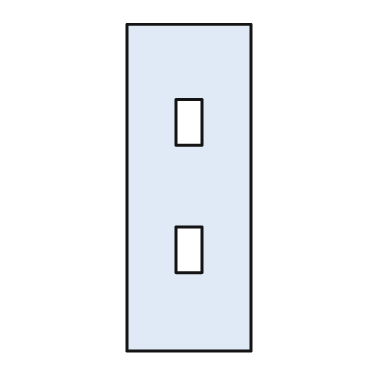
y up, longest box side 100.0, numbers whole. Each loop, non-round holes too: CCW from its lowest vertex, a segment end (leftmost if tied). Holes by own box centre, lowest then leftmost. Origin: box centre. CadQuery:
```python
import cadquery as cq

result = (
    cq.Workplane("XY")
    .moveTo(-19.0, -50.0)
    .lineTo(19.0, -50.0)
    .lineTo(19.0, 50.0)
    .lineTo(-19.0, 50.0)
    .close()
    .moveTo(-4.0, -26.0)
    .lineTo(4.0, -26.0)
    .lineTo(4.0, -12.0)
    .lineTo(-4.0, -12.0)
    .close()
    .moveTo(-4.0, 13.0)
    .lineTo(4.0, 13.0)
    .lineTo(4.0, 27.0)
    .lineTo(-4.0, 27.0)
    .close()
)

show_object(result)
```